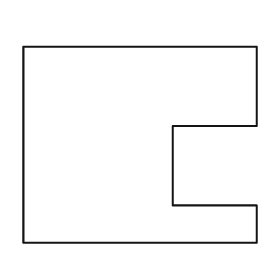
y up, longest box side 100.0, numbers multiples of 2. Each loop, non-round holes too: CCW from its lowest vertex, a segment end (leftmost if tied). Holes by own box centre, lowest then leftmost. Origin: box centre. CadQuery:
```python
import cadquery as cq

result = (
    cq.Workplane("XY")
    .moveTo(-50.0, -42.0)
    .lineTo(50.0, -42.0)
    .lineTo(50.0, -26.0)
    .lineTo(14.0, -26.0)
    .lineTo(14.0, 8.0)
    .lineTo(50.0, 8.0)
    .lineTo(50.0, 42.0)
    .lineTo(-50.0, 42.0)
    .close()
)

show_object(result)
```